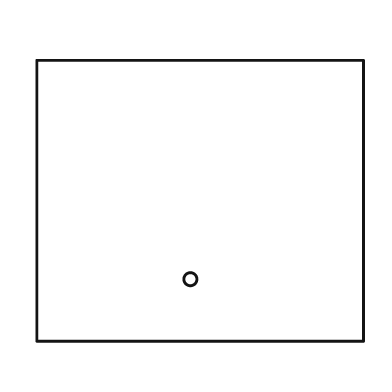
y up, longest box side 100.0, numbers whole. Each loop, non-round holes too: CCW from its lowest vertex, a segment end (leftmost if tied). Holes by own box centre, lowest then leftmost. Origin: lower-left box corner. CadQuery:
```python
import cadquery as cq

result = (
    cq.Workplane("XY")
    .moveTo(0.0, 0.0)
    .lineTo(100.0, 0.0)
    .lineTo(100.0, 86.0)
    .lineTo(0.0, 86.0)
    .close()
    .moveTo(47.0, 19.0)
    .circle(2.0)
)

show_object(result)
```